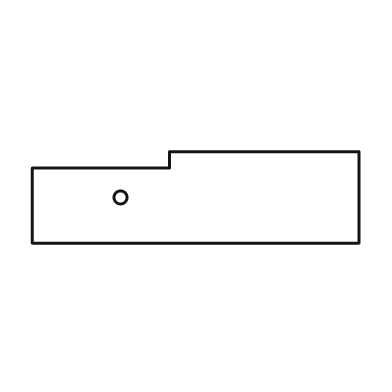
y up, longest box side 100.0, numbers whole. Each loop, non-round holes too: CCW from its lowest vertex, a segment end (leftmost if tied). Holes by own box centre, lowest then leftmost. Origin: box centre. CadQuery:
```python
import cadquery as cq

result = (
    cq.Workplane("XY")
    .moveTo(-50.0, -14.0)
    .lineTo(50.0, -14.0)
    .lineTo(50.0, 14.0)
    .lineTo(-8.0, 14.0)
    .lineTo(-8.0, 9.0)
    .lineTo(-50.0, 9.0)
    .close()
    .moveTo(-23.0, 0.0)
    .circle(2.0)
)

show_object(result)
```